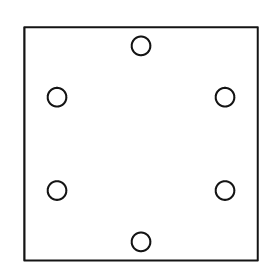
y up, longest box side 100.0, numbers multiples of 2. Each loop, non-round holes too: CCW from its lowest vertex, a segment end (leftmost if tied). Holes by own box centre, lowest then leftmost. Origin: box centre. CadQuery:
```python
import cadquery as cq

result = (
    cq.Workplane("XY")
    .moveTo(-50.0, -50.0)
    .lineTo(50.0, -50.0)
    .lineTo(50.0, 50.0)
    .lineTo(-50.0, 50.0)
    .close()
    .moveTo(0.0, -42.0)
    .circle(4.0)
    .moveTo(-36.0, -20.0)
    .circle(4.0)
    .moveTo(36.0, -20.0)
    .circle(4.0)
    .moveTo(-36.0, 20.0)
    .circle(4.0)
    .moveTo(36.0, 20.0)
    .circle(4.0)
    .moveTo(0.0, 42.0)
    .circle(4.0)
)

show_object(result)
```